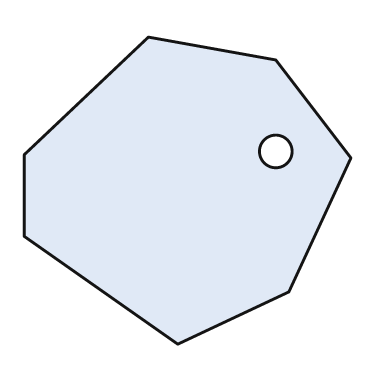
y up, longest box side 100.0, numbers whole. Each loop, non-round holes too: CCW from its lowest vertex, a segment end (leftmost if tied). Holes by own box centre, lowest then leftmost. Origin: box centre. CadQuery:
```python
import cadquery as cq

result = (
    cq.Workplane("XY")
    .moveTo(-3.0, -47.0)
    .lineTo(31.0, -31.0)
    .lineTo(50.0, 10.0)
    .lineTo(27.0, 40.0)
    .lineTo(-12.0, 47.0)
    .lineTo(-50.0, 11.0)
    .lineTo(-50.0, -14.0)
    .close()
    .moveTo(27.0, 12.0)
    .circle(5.0)
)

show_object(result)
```